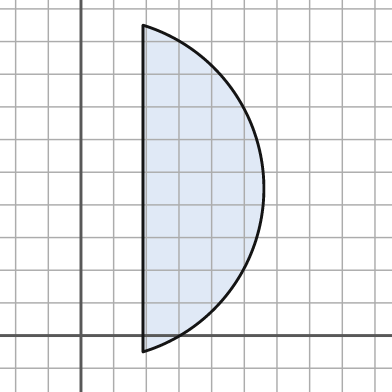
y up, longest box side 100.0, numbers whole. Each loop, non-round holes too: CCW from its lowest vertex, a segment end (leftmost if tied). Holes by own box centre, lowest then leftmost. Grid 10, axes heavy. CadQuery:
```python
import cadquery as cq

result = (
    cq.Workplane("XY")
    .moveTo(19.0, -5.0)
    .threePointArc((56.0, 45.0), (19.0, 95.0))
    .close()
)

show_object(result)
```